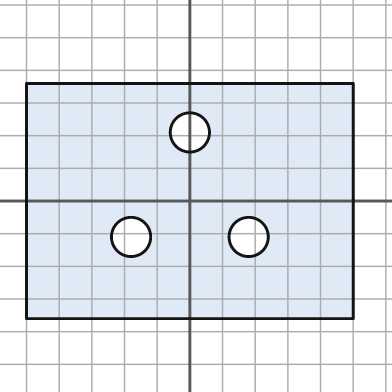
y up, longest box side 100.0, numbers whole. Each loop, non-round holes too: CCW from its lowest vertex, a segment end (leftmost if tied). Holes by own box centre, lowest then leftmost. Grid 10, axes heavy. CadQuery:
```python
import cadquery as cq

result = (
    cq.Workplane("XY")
    .moveTo(-50.0, -36.0)
    .lineTo(50.0, -36.0)
    .lineTo(50.0, 36.0)
    .lineTo(-50.0, 36.0)
    .close()
    .moveTo(-18.0, -11.0)
    .circle(6.0)
    .moveTo(18.0, -11.0)
    .circle(6.0)
    .moveTo(0.0, 21.0)
    .circle(6.0)
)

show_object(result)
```